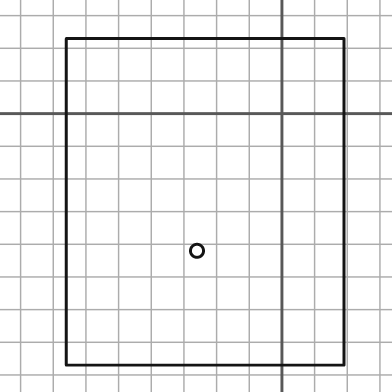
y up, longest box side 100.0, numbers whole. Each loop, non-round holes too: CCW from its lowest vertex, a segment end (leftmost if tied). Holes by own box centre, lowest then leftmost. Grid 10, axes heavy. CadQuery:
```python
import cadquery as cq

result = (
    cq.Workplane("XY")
    .moveTo(-66.0, -77.0)
    .lineTo(19.0, -77.0)
    .lineTo(19.0, 23.0)
    .lineTo(-66.0, 23.0)
    .close()
    .moveTo(-26.0, -42.0)
    .circle(2.0)
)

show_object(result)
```